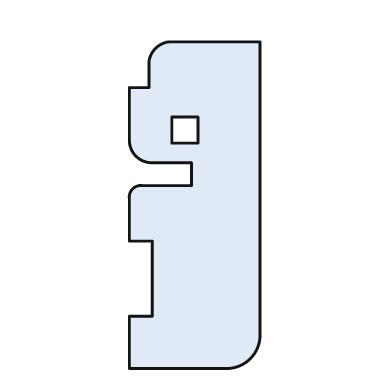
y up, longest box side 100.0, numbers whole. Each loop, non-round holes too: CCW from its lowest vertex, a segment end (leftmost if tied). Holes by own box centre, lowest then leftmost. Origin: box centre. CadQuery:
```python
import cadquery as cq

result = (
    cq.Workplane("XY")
    .moveTo(-20.0, -50.0)
    .lineTo(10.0, -50.0)
    .threePointArc((17.0, -47.0), (20.0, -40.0))
    .lineTo(20.0, 50.0)
    .lineTo(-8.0, 50.0)
    .threePointArc((-12.0, 48.0), (-14.0, 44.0))
    .lineTo(-14.0, 36.0)
    .lineTo(-20.0, 36.0)
    .lineTo(-20.0, 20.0)
    .threePointArc((-18.0, 15.0), (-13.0, 13.0))
    .lineTo(-1.0, 13.0)
    .lineTo(-1.0, 6.0)
    .lineTo(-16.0, 6.0)
    .threePointArc((-19.0, 5.0), (-20.0, 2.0))
    .lineTo(-20.0, -11.0)
    .lineTo(-13.0, -11.0)
    .lineTo(-13.0, -34.0)
    .lineTo(-20.0, -34.0)
    .close()
    .moveTo(-7.0, 19.0)
    .lineTo(1.0, 19.0)
    .lineTo(1.0, 27.0)
    .lineTo(-7.0, 27.0)
    .close()
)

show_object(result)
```